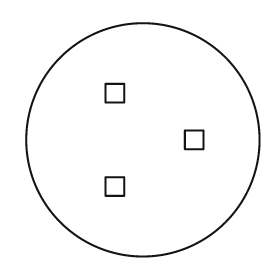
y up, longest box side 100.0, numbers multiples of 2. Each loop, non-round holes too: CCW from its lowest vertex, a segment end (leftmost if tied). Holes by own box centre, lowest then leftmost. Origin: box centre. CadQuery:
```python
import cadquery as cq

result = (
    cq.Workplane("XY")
    .moveTo(0.0, 0.0)
    .circle(50.0)
    .moveTo(-16.0, -24.0)
    .lineTo(-8.0, -24.0)
    .lineTo(-8.0, -16.0)
    .lineTo(-16.0, -16.0)
    .close()
    .moveTo(18.0, -4.0)
    .lineTo(26.0, -4.0)
    .lineTo(26.0, 4.0)
    .lineTo(18.0, 4.0)
    .close()
    .moveTo(-16.0, 16.0)
    .lineTo(-8.0, 16.0)
    .lineTo(-8.0, 24.0)
    .lineTo(-16.0, 24.0)
    .close()
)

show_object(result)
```